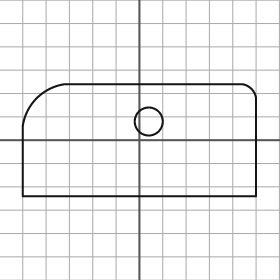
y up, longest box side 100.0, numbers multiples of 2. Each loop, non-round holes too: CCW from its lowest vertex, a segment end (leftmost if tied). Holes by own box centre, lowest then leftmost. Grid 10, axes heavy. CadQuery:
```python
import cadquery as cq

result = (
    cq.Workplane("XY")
    .moveTo(-50.0, -24.0)
    .lineTo(50.0, -24.0)
    .lineTo(50.0, 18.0)
    .threePointArc((48.0, 22.0), (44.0, 24.0))
    .lineTo(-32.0, 24.0)
    .threePointArc((-44.0, 18.0), (-50.0, 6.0))
    .close()
    .moveTo(4.0, 8.0)
    .circle(6.0)
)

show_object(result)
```